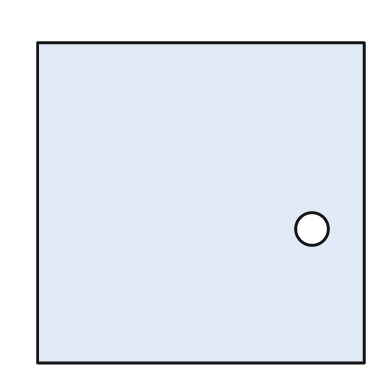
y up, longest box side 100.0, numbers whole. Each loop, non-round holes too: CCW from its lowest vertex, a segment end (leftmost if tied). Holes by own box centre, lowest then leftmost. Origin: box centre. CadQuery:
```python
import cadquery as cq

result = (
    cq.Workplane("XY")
    .moveTo(-50.0, -49.0)
    .lineTo(50.0, -49.0)
    .lineTo(50.0, 49.0)
    .lineTo(-50.0, 49.0)
    .close()
    .moveTo(34.0, -8.0)
    .circle(5.0)
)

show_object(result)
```